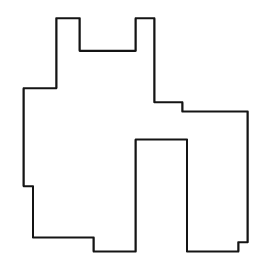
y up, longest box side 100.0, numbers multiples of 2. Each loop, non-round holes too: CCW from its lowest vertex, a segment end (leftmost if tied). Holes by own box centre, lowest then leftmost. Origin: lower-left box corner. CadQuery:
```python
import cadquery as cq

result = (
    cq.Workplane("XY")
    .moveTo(30.0, 0.0)
    .lineTo(48.0, 0.0)
    .lineTo(48.0, 48.0)
    .lineTo(70.0, 48.0)
    .lineTo(70.0, 0.0)
    .lineTo(92.0, 0.0)
    .lineTo(92.0, 4.0)
    .lineTo(96.0, 4.0)
    .lineTo(96.0, 60.0)
    .lineTo(68.0, 60.0)
    .lineTo(68.0, 64.0)
    .lineTo(56.0, 64.0)
    .lineTo(56.0, 100.0)
    .lineTo(48.0, 100.0)
    .lineTo(48.0, 86.0)
    .lineTo(24.0, 86.0)
    .lineTo(24.0, 100.0)
    .lineTo(14.0, 100.0)
    .lineTo(14.0, 70.0)
    .lineTo(0.0, 70.0)
    .lineTo(0.0, 28.0)
    .lineTo(4.0, 28.0)
    .lineTo(4.0, 6.0)
    .lineTo(30.0, 6.0)
    .close()
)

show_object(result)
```